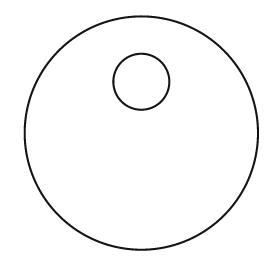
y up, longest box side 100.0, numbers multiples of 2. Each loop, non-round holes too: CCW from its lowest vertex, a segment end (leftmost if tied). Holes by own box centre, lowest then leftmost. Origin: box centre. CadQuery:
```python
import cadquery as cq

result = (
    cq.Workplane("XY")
    .moveTo(0.0, 0.0)
    .circle(50.0)
    .moveTo(0.0, 22.0)
    .circle(12.0)
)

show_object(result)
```